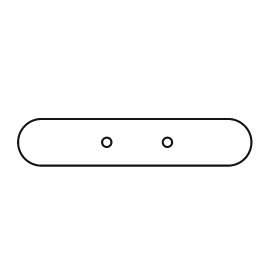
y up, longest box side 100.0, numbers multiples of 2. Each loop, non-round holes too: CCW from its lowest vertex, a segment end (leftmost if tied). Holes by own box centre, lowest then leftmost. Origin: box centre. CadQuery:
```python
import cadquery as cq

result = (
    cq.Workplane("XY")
    .moveTo(-40.0, -10.0)
    .lineTo(40.0, -10.0)
    .threePointArc((50.0, 0.0), (40.0, 10.0))
    .lineTo(-40.0, 10.0)
    .threePointArc((-50.0, 0.0), (-40.0, -10.0))
    .close()
    .moveTo(-12.0, 0.0)
    .circle(2.0)
    .moveTo(14.0, 0.0)
    .circle(2.0)
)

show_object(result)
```